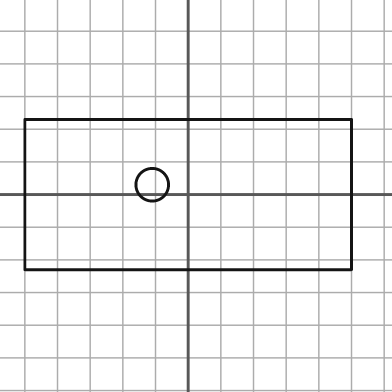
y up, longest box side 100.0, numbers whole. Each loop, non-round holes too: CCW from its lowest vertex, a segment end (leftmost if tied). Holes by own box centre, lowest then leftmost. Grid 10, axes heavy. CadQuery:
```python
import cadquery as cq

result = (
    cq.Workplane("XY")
    .moveTo(-50.0, -23.0)
    .lineTo(50.0, -23.0)
    .lineTo(50.0, 23.0)
    .lineTo(-50.0, 23.0)
    .close()
    .moveTo(-11.0, 3.0)
    .circle(5.0)
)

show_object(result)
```